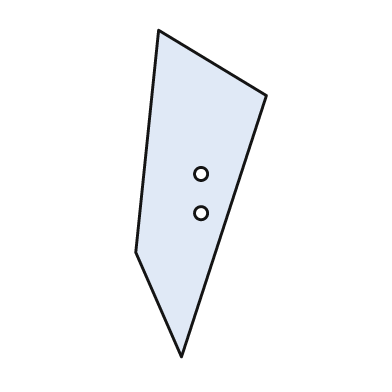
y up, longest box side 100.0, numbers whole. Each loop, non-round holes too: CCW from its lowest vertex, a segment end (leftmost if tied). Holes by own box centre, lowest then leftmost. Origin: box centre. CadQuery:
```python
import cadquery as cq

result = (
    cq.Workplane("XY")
    .moveTo(-6.0, -50.0)
    .lineTo(20.0, 30.0)
    .lineTo(-13.0, 50.0)
    .lineTo(-20.0, -18.0)
    .close()
    .moveTo(0.0, -6.0)
    .circle(2.0)
    .moveTo(0.0, 6.0)
    .circle(2.0)
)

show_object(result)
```